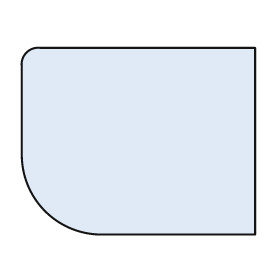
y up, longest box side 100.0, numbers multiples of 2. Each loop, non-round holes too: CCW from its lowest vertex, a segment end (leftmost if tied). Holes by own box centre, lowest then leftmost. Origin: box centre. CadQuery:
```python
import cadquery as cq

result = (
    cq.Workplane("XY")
    .moveTo(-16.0, -40.0)
    .lineTo(50.0, -40.0)
    .lineTo(50.0, 40.0)
    .lineTo(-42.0, 40.0)
    .threePointArc((-48.0, 38.0), (-50.0, 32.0))
    .lineTo(-50.0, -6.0)
    .threePointArc((-40.0, -30.0), (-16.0, -40.0))
    .close()
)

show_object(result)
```